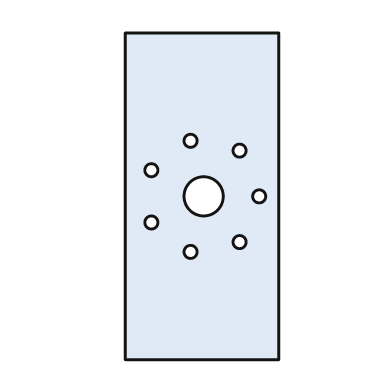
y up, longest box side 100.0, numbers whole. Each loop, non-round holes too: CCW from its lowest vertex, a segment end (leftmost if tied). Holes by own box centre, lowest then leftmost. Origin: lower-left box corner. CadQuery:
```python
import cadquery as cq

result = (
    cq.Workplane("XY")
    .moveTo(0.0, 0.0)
    .lineTo(47.0, 0.0)
    .lineTo(47.0, 100.0)
    .lineTo(0.0, 100.0)
    .close()
    .moveTo(20.0, 33.0)
    .circle(2.0)
    .moveTo(35.0, 36.0)
    .circle(2.0)
    .moveTo(8.0, 42.0)
    .circle(2.0)
    .moveTo(24.0, 50.0)
    .circle(6.0)
    .moveTo(41.0, 50.0)
    .circle(2.0)
    .moveTo(8.0, 58.0)
    .circle(2.0)
    .moveTo(35.0, 64.0)
    .circle(2.0)
    .moveTo(20.0, 67.0)
    .circle(2.0)
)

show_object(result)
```